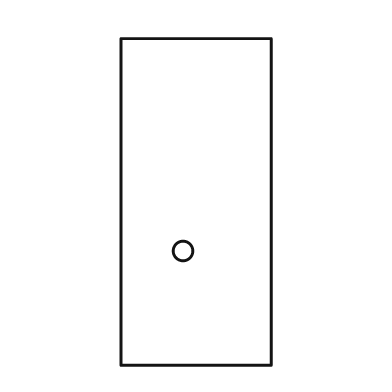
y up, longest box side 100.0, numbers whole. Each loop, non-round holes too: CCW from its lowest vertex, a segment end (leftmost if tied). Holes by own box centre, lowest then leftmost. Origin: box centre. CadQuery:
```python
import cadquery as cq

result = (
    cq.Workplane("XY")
    .moveTo(-23.0, -50.0)
    .lineTo(23.0, -50.0)
    .lineTo(23.0, 50.0)
    .lineTo(-23.0, 50.0)
    .close()
    .moveTo(-4.0, -15.0)
    .circle(3.0)
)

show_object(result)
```